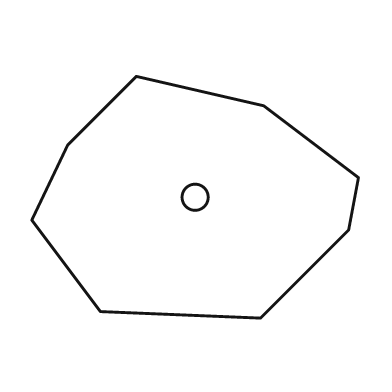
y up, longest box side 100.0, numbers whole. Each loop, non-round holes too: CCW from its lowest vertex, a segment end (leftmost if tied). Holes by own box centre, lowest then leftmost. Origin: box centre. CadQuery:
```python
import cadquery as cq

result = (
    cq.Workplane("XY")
    .moveTo(20.0, -37.0)
    .lineTo(47.0, -10.0)
    .lineTo(50.0, 6.0)
    .lineTo(21.0, 28.0)
    .lineTo(-18.0, 37.0)
    .lineTo(-39.0, 16.0)
    .lineTo(-50.0, -7.0)
    .lineTo(-29.0, -35.0)
    .close()
    .moveTo(0.0, 0.0)
    .circle(4.0)
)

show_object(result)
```